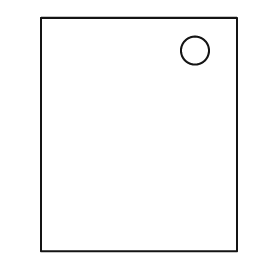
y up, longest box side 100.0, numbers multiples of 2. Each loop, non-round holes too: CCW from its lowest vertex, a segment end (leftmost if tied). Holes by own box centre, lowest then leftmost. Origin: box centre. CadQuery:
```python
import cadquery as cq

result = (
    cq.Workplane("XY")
    .moveTo(-42.0, -50.0)
    .lineTo(42.0, -50.0)
    .lineTo(42.0, 50.0)
    .lineTo(-42.0, 50.0)
    .close()
    .moveTo(24.0, 36.0)
    .circle(6.0)
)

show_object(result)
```